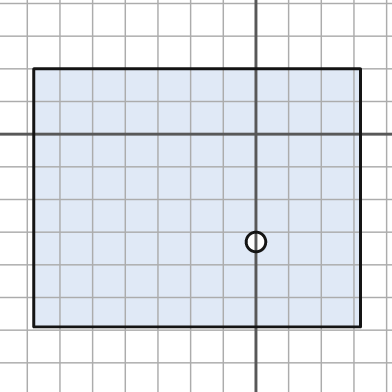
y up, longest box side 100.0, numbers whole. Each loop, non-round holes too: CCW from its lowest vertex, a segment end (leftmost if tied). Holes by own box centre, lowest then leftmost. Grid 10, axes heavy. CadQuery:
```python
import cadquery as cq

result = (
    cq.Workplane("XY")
    .moveTo(-68.0, -59.0)
    .lineTo(32.0, -59.0)
    .lineTo(32.0, 20.0)
    .lineTo(-68.0, 20.0)
    .close()
    .moveTo(0.0, -33.0)
    .circle(3.0)
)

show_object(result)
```